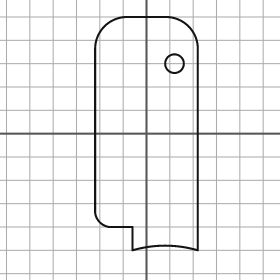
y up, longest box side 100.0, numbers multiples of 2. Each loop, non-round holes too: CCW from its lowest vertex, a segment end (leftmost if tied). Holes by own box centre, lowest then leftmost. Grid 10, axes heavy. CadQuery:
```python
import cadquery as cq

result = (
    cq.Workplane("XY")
    .moveTo(-6.0, -50.0)
    .threePointArc((8.0, -48.0), (22.0, -50.0))
    .lineTo(22.0, 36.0)
    .threePointArc((18.0, 46.0), (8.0, 50.0))
    .lineTo(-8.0, 50.0)
    .threePointArc((-18.0, 46.0), (-22.0, 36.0))
    .lineTo(-22.0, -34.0)
    .threePointArc((-20.0, -38.0), (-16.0, -40.0))
    .lineTo(-6.0, -40.0)
    .close()
    .moveTo(12.0, 30.0)
    .circle(4.0)
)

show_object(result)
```